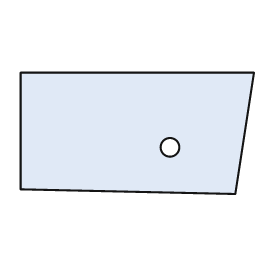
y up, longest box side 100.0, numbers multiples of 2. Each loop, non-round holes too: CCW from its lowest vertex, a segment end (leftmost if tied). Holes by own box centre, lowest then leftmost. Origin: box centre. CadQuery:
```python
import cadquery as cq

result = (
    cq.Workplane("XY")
    .moveTo(42.0, -26.0)
    .lineTo(50.0, 26.0)
    .lineTo(-50.0, 26.0)
    .lineTo(-50.0, -24.0)
    .close()
    .moveTo(14.0, -6.0)
    .circle(4.0)
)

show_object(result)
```